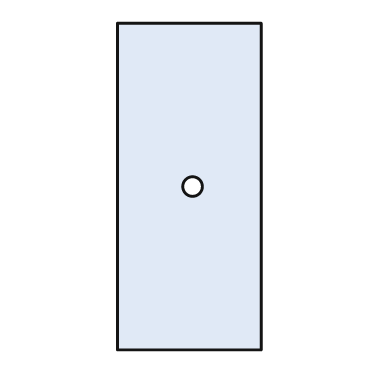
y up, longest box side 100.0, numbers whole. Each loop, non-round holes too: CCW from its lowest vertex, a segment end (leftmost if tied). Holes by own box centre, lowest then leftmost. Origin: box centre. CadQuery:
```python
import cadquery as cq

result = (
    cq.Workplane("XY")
    .moveTo(-22.0, -50.0)
    .lineTo(22.0, -50.0)
    .lineTo(22.0, 50.0)
    .lineTo(-22.0, 50.0)
    .close()
    .moveTo(1.0, 0.0)
    .circle(3.0)
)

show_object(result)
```